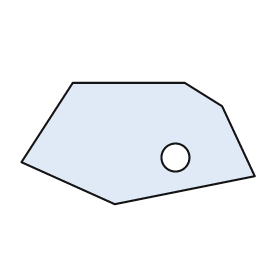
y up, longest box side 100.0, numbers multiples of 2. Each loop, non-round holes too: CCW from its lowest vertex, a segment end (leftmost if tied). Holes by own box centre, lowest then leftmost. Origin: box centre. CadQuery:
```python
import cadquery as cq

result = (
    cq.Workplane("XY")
    .moveTo(-10.0, -26.0)
    .lineTo(50.0, -14.0)
    .lineTo(36.0, 16.0)
    .lineTo(20.0, 26.0)
    .lineTo(-28.0, 26.0)
    .lineTo(-50.0, -8.0)
    .close()
    .moveTo(16.0, -6.0)
    .circle(6.0)
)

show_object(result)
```